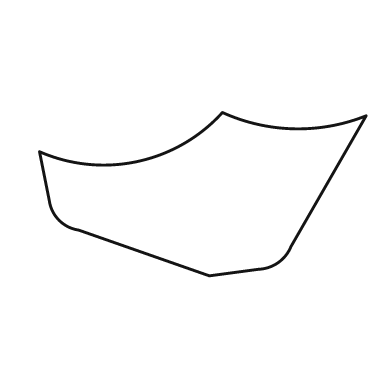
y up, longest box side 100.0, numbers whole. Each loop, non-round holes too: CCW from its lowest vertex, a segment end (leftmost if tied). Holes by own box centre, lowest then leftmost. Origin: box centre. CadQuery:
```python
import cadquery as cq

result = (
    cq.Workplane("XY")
    .moveTo(2.0, -25.0)
    .lineTo(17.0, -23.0)
    .threePointArc((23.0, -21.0), (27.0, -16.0))
    .lineTo(50.0, 24.0)
    .threePointArc((28.0, 20.0), (6.0, 25.0))
    .threePointArc((-20.0, 10.0), (-50.0, 13.0))
    .lineTo(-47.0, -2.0)
    .threePointArc((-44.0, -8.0), (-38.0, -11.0))
    .close()
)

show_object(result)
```